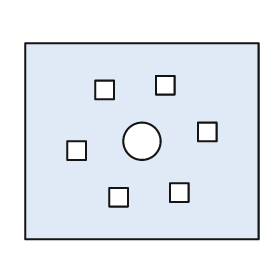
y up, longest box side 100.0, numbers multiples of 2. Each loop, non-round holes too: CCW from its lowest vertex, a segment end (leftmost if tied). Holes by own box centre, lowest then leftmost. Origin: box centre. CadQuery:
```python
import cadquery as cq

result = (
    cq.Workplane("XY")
    .moveTo(-50.0, -42.0)
    .lineTo(50.0, -42.0)
    .lineTo(50.0, 42.0)
    .lineTo(-50.0, 42.0)
    .close()
    .moveTo(-14.0, -28.0)
    .lineTo(-6.0, -28.0)
    .lineTo(-6.0, -20.0)
    .lineTo(-14.0, -20.0)
    .close()
    .moveTo(12.0, -26.0)
    .lineTo(20.0, -26.0)
    .lineTo(20.0, -18.0)
    .lineTo(12.0, -18.0)
    .close()
    .moveTo(-32.0, -8.0)
    .lineTo(-24.0, -8.0)
    .lineTo(-24.0, 0.0)
    .lineTo(-32.0, 0.0)
    .close()
    .moveTo(0.0, 0.0)
    .circle(8.0)
    .moveTo(24.0, 0.0)
    .lineTo(32.0, 0.0)
    .lineTo(32.0, 8.0)
    .lineTo(24.0, 8.0)
    .close()
    .moveTo(-20.0, 18.0)
    .lineTo(-12.0, 18.0)
    .lineTo(-12.0, 26.0)
    .lineTo(-20.0, 26.0)
    .close()
    .moveTo(6.0, 20.0)
    .lineTo(14.0, 20.0)
    .lineTo(14.0, 28.0)
    .lineTo(6.0, 28.0)
    .close()
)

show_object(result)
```